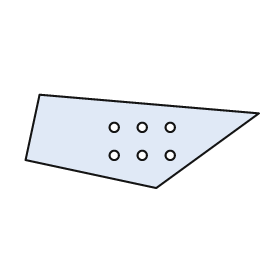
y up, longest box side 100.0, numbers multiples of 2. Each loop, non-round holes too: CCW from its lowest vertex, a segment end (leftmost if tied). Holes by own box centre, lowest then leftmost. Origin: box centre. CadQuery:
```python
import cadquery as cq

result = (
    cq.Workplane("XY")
    .moveTo(6.0, -20.0)
    .lineTo(50.0, 12.0)
    .lineTo(-44.0, 20.0)
    .lineTo(-50.0, -8.0)
    .close()
    .moveTo(-12.0, -6.0)
    .circle(2.0)
    .moveTo(0.0, -6.0)
    .circle(2.0)
    .moveTo(12.0, -6.0)
    .circle(2.0)
    .moveTo(-12.0, 6.0)
    .circle(2.0)
    .moveTo(0.0, 6.0)
    .circle(2.0)
    .moveTo(12.0, 6.0)
    .circle(2.0)
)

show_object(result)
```